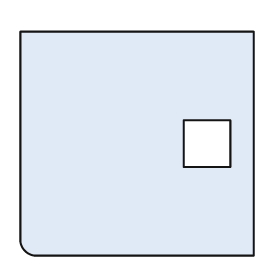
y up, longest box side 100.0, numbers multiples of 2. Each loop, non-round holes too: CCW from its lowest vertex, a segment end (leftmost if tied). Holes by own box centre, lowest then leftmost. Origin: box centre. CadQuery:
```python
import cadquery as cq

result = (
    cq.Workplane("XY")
    .moveTo(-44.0, -48.0)
    .lineTo(50.0, -48.0)
    .lineTo(50.0, 48.0)
    .lineTo(-50.0, 48.0)
    .lineTo(-50.0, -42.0)
    .threePointArc((-48.0, -46.0), (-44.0, -48.0))
    .close()
    .moveTo(20.0, -10.0)
    .lineTo(40.0, -10.0)
    .lineTo(40.0, 10.0)
    .lineTo(20.0, 10.0)
    .close()
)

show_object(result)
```